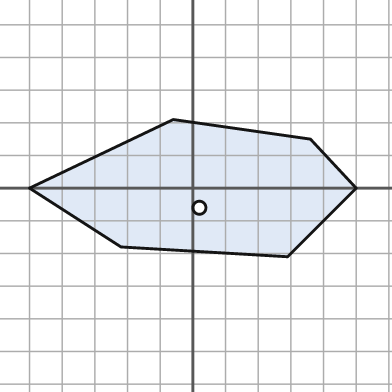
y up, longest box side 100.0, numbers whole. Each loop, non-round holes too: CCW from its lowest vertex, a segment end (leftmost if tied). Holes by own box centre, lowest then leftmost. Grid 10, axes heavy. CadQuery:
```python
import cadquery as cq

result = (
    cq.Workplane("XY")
    .moveTo(29.0, -21.0)
    .lineTo(50.0, 0.0)
    .lineTo(36.0, 15.0)
    .lineTo(-6.0, 21.0)
    .lineTo(-50.0, 0.0)
    .lineTo(-22.0, -18.0)
    .close()
    .moveTo(2.0, -6.0)
    .circle(2.0)
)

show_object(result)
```